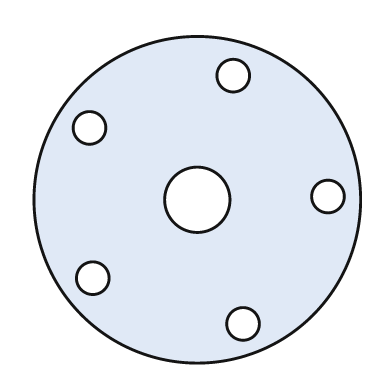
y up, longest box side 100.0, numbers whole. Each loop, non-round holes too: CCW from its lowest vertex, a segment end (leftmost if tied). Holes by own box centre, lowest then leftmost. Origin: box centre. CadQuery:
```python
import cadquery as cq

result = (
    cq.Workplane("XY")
    .moveTo(0.0, 0.0)
    .circle(50.0)
    .moveTo(14.0, -38.0)
    .circle(5.0)
    .moveTo(-32.0, -24.0)
    .circle(5.0)
    .moveTo(0.0, 0.0)
    .circle(10.0)
    .moveTo(40.0, 1.0)
    .circle(5.0)
    .moveTo(-33.0, 22.0)
    .circle(5.0)
    .moveTo(11.0, 38.0)
    .circle(5.0)
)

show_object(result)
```